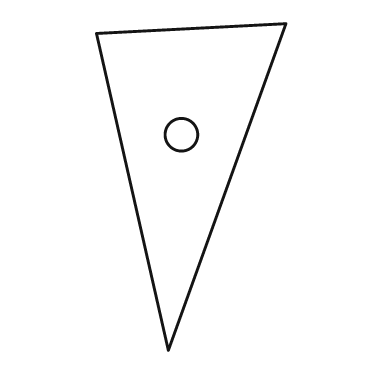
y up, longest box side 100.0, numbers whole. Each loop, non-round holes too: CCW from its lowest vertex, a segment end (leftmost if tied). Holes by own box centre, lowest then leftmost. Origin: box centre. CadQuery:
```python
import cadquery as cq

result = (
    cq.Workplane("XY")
    .moveTo(-7.0, -50.0)
    .lineTo(29.0, 50.0)
    .lineTo(-29.0, 47.0)
    .close()
    .moveTo(-3.0, 16.0)
    .circle(5.0)
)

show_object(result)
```